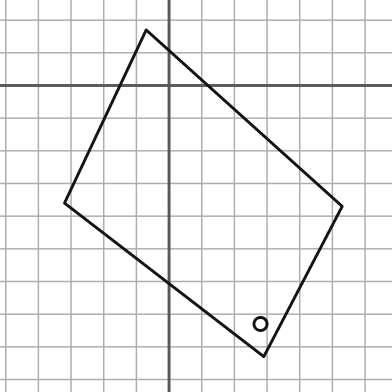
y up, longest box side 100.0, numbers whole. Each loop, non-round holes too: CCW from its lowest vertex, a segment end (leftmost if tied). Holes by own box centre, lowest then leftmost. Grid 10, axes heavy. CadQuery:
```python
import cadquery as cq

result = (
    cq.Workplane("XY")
    .moveTo(29.0, -83.0)
    .lineTo(53.0, -37.0)
    .lineTo(-7.0, 17.0)
    .lineTo(-32.0, -36.0)
    .close()
    .moveTo(28.0, -73.0)
    .circle(2.0)
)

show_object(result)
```